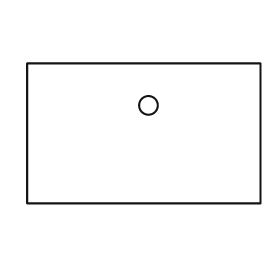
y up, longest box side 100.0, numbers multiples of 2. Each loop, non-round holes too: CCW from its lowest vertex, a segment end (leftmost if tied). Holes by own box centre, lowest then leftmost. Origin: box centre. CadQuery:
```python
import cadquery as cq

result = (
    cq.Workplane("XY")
    .moveTo(-50.0, -30.0)
    .lineTo(50.0, -30.0)
    .lineTo(50.0, 30.0)
    .lineTo(-50.0, 30.0)
    .close()
    .moveTo(2.0, 12.0)
    .circle(4.0)
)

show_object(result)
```